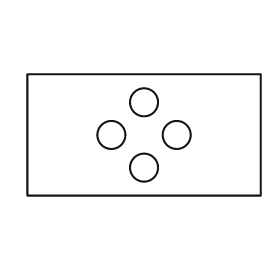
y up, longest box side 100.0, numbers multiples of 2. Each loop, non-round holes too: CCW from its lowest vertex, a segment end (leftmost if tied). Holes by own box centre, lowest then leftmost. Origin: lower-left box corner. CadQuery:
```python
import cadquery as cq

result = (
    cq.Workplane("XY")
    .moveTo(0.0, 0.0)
    .lineTo(100.0, 0.0)
    .lineTo(100.0, 52.0)
    .lineTo(0.0, 52.0)
    .close()
    .moveTo(50.0, 12.0)
    .circle(6.0)
    .moveTo(36.0, 26.0)
    .circle(6.0)
    .moveTo(64.0, 26.0)
    .circle(6.0)
    .moveTo(50.0, 40.0)
    .circle(6.0)
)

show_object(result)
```